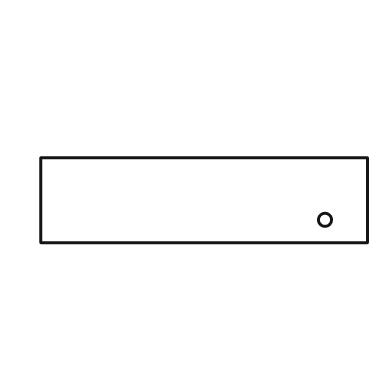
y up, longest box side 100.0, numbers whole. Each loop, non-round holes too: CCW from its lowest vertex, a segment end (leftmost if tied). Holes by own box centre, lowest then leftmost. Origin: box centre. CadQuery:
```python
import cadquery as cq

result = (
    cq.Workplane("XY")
    .moveTo(-50.0, -13.0)
    .lineTo(50.0, -13.0)
    .lineTo(50.0, 13.0)
    .lineTo(-50.0, 13.0)
    .close()
    .moveTo(37.0, -6.0)
    .circle(2.0)
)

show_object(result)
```